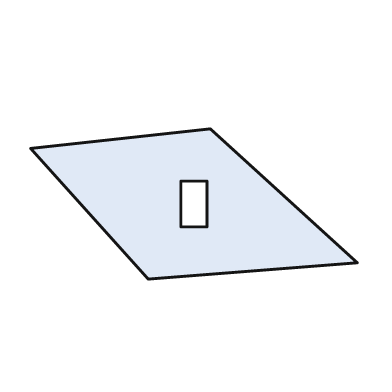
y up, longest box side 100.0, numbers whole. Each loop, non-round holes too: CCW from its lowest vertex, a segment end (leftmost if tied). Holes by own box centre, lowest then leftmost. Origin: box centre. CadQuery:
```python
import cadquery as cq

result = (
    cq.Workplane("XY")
    .moveTo(-14.0, -23.0)
    .lineTo(50.0, -18.0)
    .lineTo(5.0, 23.0)
    .lineTo(-50.0, 17.0)
    .close()
    .moveTo(-4.0, -7.0)
    .lineTo(4.0, -7.0)
    .lineTo(4.0, 7.0)
    .lineTo(-4.0, 7.0)
    .close()
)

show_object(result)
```